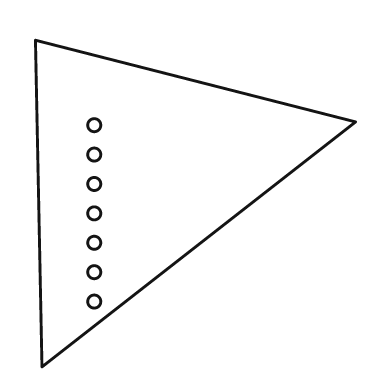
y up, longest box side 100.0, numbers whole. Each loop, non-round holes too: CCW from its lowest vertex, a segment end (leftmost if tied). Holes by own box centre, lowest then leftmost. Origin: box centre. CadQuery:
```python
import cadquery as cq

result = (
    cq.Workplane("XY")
    .moveTo(-47.0, -50.0)
    .lineTo(49.0, 25.0)
    .lineTo(-49.0, 50.0)
    .close()
    .moveTo(-31.0, -30.0)
    .circle(2.0)
    .moveTo(-31.0, -21.0)
    .circle(2.0)
    .moveTo(-31.0, -12.0)
    .circle(2.0)
    .moveTo(-31.0, -3.0)
    .circle(2.0)
    .moveTo(-31.0, 6.0)
    .circle(2.0)
    .moveTo(-31.0, 15.0)
    .circle(2.0)
    .moveTo(-31.0, 24.0)
    .circle(2.0)
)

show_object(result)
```